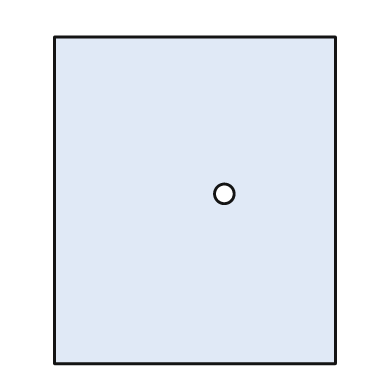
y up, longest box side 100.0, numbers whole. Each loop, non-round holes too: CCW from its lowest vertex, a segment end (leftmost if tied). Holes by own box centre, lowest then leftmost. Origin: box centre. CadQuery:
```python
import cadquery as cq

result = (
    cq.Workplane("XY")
    .moveTo(-43.0, -50.0)
    .lineTo(43.0, -50.0)
    .lineTo(43.0, 50.0)
    .lineTo(-43.0, 50.0)
    .close()
    .moveTo(9.0, 2.0)
    .circle(3.0)
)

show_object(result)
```